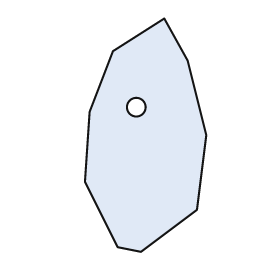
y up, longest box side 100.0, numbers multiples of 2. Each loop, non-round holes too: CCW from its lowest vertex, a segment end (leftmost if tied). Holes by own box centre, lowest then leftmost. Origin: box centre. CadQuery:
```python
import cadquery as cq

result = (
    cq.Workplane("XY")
    .moveTo(-2.0, -50.0)
    .lineTo(22.0, -32.0)
    .lineTo(26.0, 0.0)
    .lineTo(18.0, 32.0)
    .lineTo(8.0, 50.0)
    .lineTo(-14.0, 36.0)
    .lineTo(-24.0, 10.0)
    .lineTo(-26.0, -20.0)
    .lineTo(-12.0, -48.0)
    .close()
    .moveTo(-4.0, 12.0)
    .circle(4.0)
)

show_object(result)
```